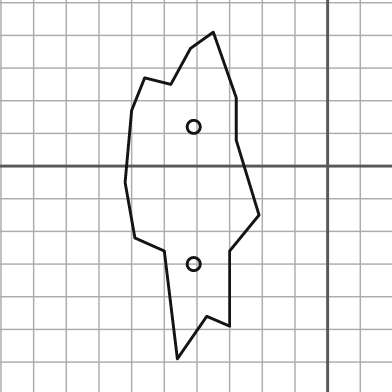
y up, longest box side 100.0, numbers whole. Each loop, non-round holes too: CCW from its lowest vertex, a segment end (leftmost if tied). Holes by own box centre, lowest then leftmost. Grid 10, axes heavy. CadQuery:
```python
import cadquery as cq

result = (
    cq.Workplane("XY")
    .moveTo(-46.0, -59.0)
    .lineTo(-37.0, -46.0)
    .lineTo(-30.0, -49.0)
    .lineTo(-30.0, -26.0)
    .lineTo(-21.0, -15.0)
    .lineTo(-28.0, 8.0)
    .lineTo(-28.0, 21.0)
    .lineTo(-35.0, 41.0)
    .lineTo(-42.0, 36.0)
    .lineTo(-48.0, 25.0)
    .lineTo(-56.0, 27.0)
    .lineTo(-60.0, 17.0)
    .lineTo(-62.0, -5.0)
    .lineTo(-59.0, -22.0)
    .lineTo(-50.0, -26.0)
    .close()
    .moveTo(-41.0, -30.0)
    .circle(2.0)
    .moveTo(-41.0, 12.0)
    .circle(2.0)
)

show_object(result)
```